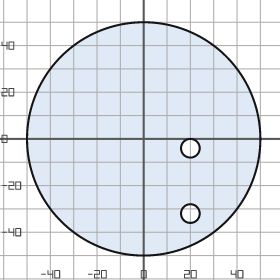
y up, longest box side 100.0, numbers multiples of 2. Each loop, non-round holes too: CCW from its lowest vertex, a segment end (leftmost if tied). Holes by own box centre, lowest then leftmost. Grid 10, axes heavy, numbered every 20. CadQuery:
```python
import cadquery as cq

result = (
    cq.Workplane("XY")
    .moveTo(0.0, 0.0)
    .circle(50.0)
    .moveTo(20.0, -32.0)
    .circle(4.0)
    .moveTo(20.0, -4.0)
    .circle(4.0)
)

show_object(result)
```